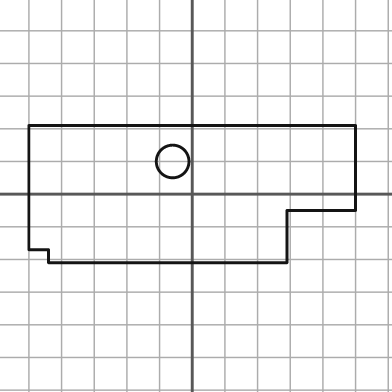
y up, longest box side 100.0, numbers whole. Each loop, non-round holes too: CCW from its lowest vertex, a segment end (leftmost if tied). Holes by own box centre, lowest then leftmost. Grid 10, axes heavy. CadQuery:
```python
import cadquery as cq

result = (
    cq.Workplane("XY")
    .moveTo(-44.0, -21.0)
    .lineTo(29.0, -21.0)
    .lineTo(29.0, -5.0)
    .lineTo(50.0, -5.0)
    .lineTo(50.0, 21.0)
    .lineTo(-50.0, 21.0)
    .lineTo(-50.0, -17.0)
    .lineTo(-44.0, -17.0)
    .close()
    .moveTo(-6.0, 10.0)
    .circle(5.0)
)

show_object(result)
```